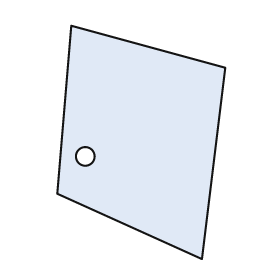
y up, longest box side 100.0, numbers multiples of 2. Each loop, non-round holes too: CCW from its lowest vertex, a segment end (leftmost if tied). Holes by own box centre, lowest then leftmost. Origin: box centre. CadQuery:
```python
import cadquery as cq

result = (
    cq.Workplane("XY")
    .moveTo(26.0, -50.0)
    .lineTo(36.0, 32.0)
    .lineTo(-30.0, 50.0)
    .lineTo(-36.0, -22.0)
    .close()
    .moveTo(-24.0, -6.0)
    .circle(4.0)
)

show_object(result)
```